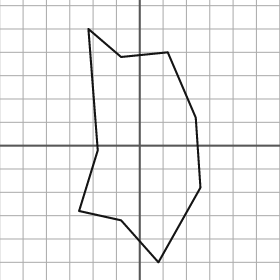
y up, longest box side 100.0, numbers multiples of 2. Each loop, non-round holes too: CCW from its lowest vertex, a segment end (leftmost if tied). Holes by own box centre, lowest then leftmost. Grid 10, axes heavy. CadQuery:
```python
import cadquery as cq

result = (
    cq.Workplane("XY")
    .moveTo(8.0, -50.0)
    .lineTo(26.0, -18.0)
    .lineTo(24.0, 12.0)
    .lineTo(12.0, 40.0)
    .lineTo(-8.0, 38.0)
    .lineTo(-22.0, 50.0)
    .lineTo(-18.0, -2.0)
    .lineTo(-26.0, -28.0)
    .lineTo(-8.0, -32.0)
    .close()
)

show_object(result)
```